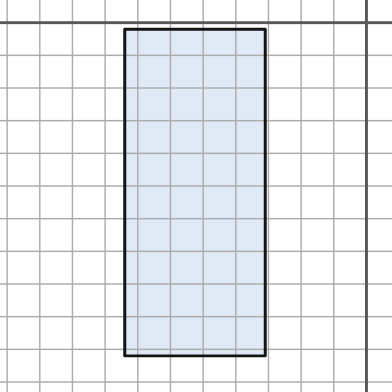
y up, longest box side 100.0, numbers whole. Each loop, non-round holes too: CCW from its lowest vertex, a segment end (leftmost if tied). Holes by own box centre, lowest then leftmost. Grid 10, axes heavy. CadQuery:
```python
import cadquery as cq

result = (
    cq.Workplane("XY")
    .moveTo(-74.0, -102.0)
    .lineTo(-31.0, -102.0)
    .lineTo(-31.0, -2.0)
    .lineTo(-74.0, -2.0)
    .close()
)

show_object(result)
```